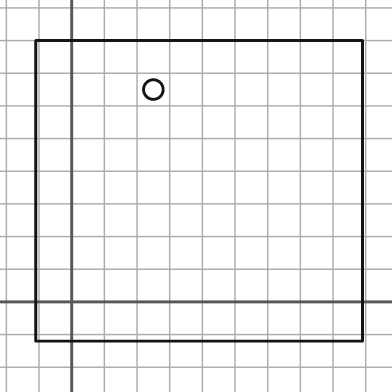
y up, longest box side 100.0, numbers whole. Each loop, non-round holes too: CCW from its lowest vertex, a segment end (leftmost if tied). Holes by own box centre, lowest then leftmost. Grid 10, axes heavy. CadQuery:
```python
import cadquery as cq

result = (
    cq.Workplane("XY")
    .moveTo(-11.0, -12.0)
    .lineTo(89.0, -12.0)
    .lineTo(89.0, 80.0)
    .lineTo(-11.0, 80.0)
    .close()
    .moveTo(25.0, 65.0)
    .circle(3.0)
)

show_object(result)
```